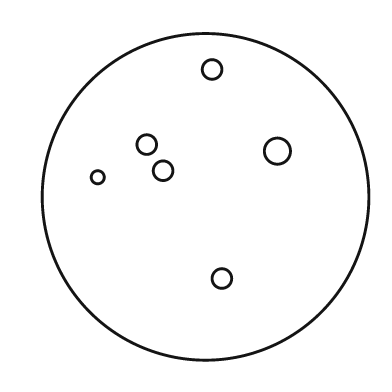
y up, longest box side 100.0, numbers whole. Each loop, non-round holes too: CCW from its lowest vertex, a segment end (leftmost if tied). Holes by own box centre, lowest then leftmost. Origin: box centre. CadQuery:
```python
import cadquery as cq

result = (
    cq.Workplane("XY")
    .moveTo(0.0, 0.0)
    .circle(50.0)
    .moveTo(5.0, -25.0)
    .circle(3.0)
    .moveTo(-33.0, 6.0)
    .circle(2.0)
    .moveTo(-13.0, 8.0)
    .circle(3.0)
    .moveTo(22.0, 14.0)
    .circle(4.0)
    .moveTo(-18.0, 16.0)
    .circle(3.0)
    .moveTo(2.0, 39.0)
    .circle(3.0)
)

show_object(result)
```